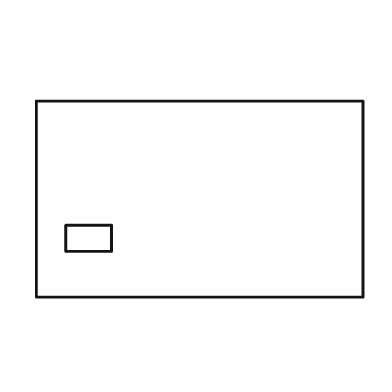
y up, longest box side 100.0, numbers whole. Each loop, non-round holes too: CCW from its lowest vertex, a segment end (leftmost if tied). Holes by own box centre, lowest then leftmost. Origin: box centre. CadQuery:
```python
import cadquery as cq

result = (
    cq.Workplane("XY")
    .moveTo(-50.0, -30.0)
    .lineTo(50.0, -30.0)
    .lineTo(50.0, 30.0)
    .lineTo(-50.0, 30.0)
    .close()
    .moveTo(-41.0, -16.0)
    .lineTo(-27.0, -16.0)
    .lineTo(-27.0, -8.0)
    .lineTo(-41.0, -8.0)
    .close()
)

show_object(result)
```